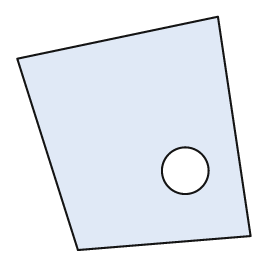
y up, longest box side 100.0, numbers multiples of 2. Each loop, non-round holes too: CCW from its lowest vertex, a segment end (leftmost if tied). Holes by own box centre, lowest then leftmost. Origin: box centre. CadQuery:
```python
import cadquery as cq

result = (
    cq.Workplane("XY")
    .moveTo(-24.0, -50.0)
    .lineTo(50.0, -44.0)
    .lineTo(36.0, 50.0)
    .lineTo(-50.0, 32.0)
    .close()
    .moveTo(22.0, -16.0)
    .circle(10.0)
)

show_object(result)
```